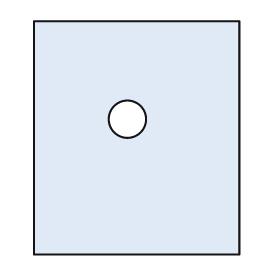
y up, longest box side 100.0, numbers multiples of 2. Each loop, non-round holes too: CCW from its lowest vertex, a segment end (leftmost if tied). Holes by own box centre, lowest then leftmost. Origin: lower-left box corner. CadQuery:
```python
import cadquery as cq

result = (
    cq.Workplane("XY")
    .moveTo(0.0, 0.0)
    .lineTo(88.0, 0.0)
    .lineTo(88.0, 100.0)
    .lineTo(0.0, 100.0)
    .close()
    .moveTo(40.0, 58.0)
    .circle(8.0)
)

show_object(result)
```